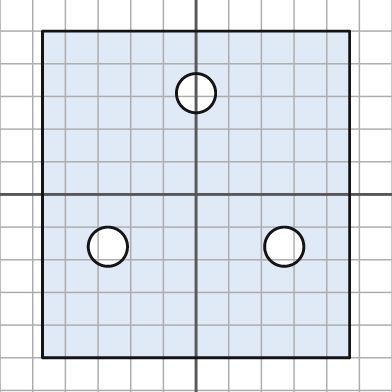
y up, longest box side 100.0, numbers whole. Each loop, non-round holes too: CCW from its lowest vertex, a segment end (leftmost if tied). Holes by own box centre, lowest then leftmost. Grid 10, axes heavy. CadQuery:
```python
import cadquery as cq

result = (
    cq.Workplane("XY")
    .moveTo(-47.0, -50.0)
    .lineTo(47.0, -50.0)
    .lineTo(47.0, 50.0)
    .lineTo(-47.0, 50.0)
    .close()
    .moveTo(-27.0, -16.0)
    .circle(6.0)
    .moveTo(27.0, -16.0)
    .circle(6.0)
    .moveTo(0.0, 31.0)
    .circle(6.0)
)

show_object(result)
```